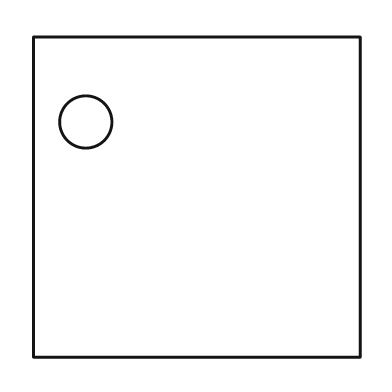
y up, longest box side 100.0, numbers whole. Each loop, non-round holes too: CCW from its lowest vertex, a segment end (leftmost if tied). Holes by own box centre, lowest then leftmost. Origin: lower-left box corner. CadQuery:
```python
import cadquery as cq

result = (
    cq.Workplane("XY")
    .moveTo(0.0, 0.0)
    .lineTo(100.0, 0.0)
    .lineTo(100.0, 98.0)
    .lineTo(0.0, 98.0)
    .close()
    .moveTo(16.0, 72.0)
    .circle(8.0)
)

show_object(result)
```